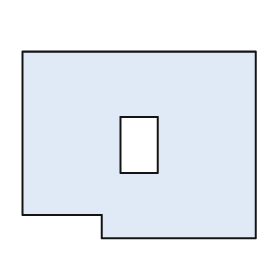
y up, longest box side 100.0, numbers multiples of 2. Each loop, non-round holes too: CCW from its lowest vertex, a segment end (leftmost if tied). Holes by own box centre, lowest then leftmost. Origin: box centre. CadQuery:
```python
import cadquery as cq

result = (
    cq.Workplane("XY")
    .moveTo(-16.0, -40.0)
    .lineTo(50.0, -40.0)
    .lineTo(50.0, 40.0)
    .lineTo(-50.0, 40.0)
    .lineTo(-50.0, -30.0)
    .lineTo(-16.0, -30.0)
    .close()
    .moveTo(-8.0, -12.0)
    .lineTo(8.0, -12.0)
    .lineTo(8.0, 12.0)
    .lineTo(-8.0, 12.0)
    .close()
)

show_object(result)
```